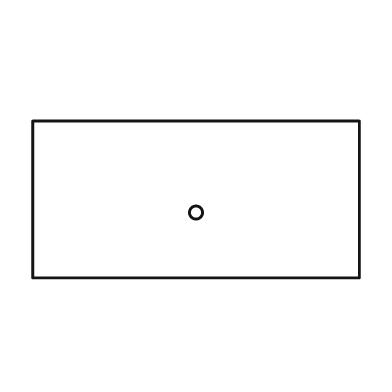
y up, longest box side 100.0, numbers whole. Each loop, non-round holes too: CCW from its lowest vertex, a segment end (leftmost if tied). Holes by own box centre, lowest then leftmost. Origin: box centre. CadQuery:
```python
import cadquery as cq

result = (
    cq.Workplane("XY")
    .moveTo(-50.0, -24.0)
    .lineTo(50.0, -24.0)
    .lineTo(50.0, 24.0)
    .lineTo(-50.0, 24.0)
    .close()
    .moveTo(0.0, -4.0)
    .circle(2.0)
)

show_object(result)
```